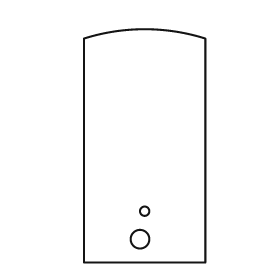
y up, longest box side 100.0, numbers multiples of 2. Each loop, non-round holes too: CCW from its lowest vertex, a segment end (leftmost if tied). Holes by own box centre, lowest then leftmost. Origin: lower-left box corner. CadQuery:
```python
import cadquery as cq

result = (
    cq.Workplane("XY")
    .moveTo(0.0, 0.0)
    .lineTo(52.0, 0.0)
    .lineTo(52.0, 96.0)
    .threePointArc((26.0, 100.0), (0.0, 96.0))
    .close()
    .moveTo(24.0, 10.0)
    .circle(4.0)
    .moveTo(26.0, 22.0)
    .circle(2.0)
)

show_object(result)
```